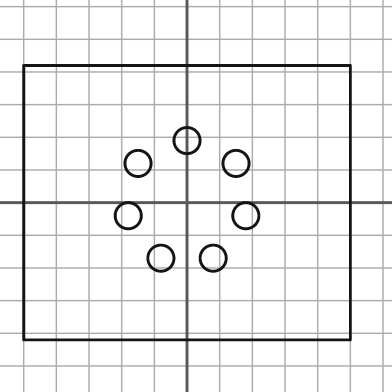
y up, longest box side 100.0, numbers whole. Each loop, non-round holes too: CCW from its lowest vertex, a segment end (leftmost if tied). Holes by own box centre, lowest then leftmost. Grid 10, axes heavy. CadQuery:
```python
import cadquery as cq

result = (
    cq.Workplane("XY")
    .moveTo(-50.0, -42.0)
    .lineTo(50.0, -42.0)
    .lineTo(50.0, 42.0)
    .lineTo(-50.0, 42.0)
    .close()
    .moveTo(-8.0, -17.0)
    .circle(4.0)
    .moveTo(8.0, -17.0)
    .circle(4.0)
    .moveTo(-18.0, -4.0)
    .circle(4.0)
    .moveTo(18.0, -4.0)
    .circle(4.0)
    .moveTo(-15.0, 12.0)
    .circle(4.0)
    .moveTo(15.0, 12.0)
    .circle(4.0)
    .moveTo(0.0, 19.0)
    .circle(4.0)
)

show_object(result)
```